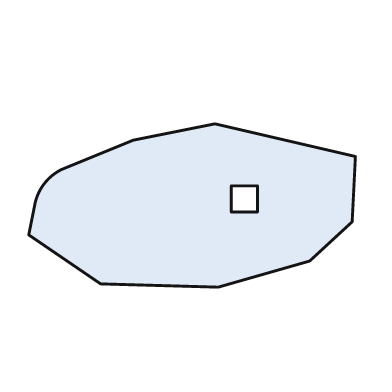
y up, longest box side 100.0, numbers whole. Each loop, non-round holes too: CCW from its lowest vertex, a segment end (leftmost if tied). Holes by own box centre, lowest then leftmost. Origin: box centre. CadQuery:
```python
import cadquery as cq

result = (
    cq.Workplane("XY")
    .moveTo(8.0, -25.0)
    .lineTo(36.0, -17.0)
    .lineTo(49.0, -5.0)
    .lineTo(50.0, 15.0)
    .lineTo(7.0, 25.0)
    .lineTo(-18.0, 20.0)
    .lineTo(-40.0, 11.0)
    .threePointArc((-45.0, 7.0), (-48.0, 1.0))
    .lineTo(-50.0, -9.0)
    .lineTo(-28.0, -24.0)
    .close()
    .moveTo(12.0, -2.0)
    .lineTo(20.0, -2.0)
    .lineTo(20.0, 6.0)
    .lineTo(12.0, 6.0)
    .close()
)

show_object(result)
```